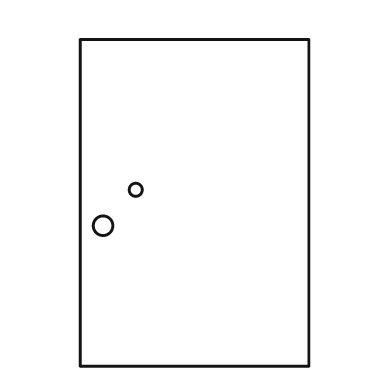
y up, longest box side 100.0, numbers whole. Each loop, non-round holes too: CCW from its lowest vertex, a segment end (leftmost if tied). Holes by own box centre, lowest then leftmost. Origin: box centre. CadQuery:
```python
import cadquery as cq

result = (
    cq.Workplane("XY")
    .moveTo(-35.0, -50.0)
    .lineTo(35.0, -50.0)
    .lineTo(35.0, 50.0)
    .lineTo(-35.0, 50.0)
    .close()
    .moveTo(-28.0, -7.0)
    .circle(3.0)
    .moveTo(-18.0, 4.0)
    .circle(2.0)
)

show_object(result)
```